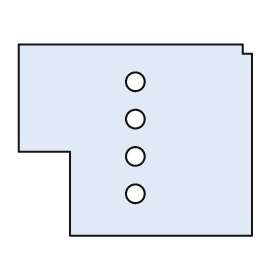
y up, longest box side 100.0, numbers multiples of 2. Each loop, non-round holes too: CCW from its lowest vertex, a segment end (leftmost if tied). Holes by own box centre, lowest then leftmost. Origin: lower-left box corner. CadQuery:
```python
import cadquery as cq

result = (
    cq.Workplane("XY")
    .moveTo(22.0, 0.0)
    .lineTo(100.0, 0.0)
    .lineTo(100.0, 78.0)
    .lineTo(96.0, 78.0)
    .lineTo(96.0, 82.0)
    .lineTo(0.0, 82.0)
    .lineTo(0.0, 36.0)
    .lineTo(22.0, 36.0)
    .close()
    .moveTo(50.0, 18.0)
    .circle(4.0)
    .moveTo(50.0, 34.0)
    .circle(4.0)
    .moveTo(50.0, 50.0)
    .circle(4.0)
    .moveTo(50.0, 66.0)
    .circle(4.0)
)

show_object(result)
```